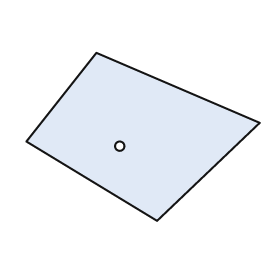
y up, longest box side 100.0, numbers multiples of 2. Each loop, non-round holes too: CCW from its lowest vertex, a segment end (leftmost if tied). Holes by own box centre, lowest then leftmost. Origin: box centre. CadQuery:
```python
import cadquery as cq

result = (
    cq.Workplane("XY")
    .moveTo(6.0, -36.0)
    .lineTo(50.0, 6.0)
    .lineTo(-20.0, 36.0)
    .lineTo(-50.0, -2.0)
    .close()
    .moveTo(-10.0, -4.0)
    .circle(2.0)
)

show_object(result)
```